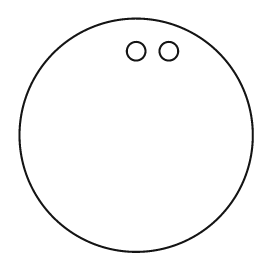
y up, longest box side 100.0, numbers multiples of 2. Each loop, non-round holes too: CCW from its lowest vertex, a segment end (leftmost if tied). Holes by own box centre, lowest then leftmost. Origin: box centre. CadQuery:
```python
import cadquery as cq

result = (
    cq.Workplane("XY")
    .moveTo(0.0, 0.0)
    .circle(50.0)
    .moveTo(0.0, 36.0)
    .circle(4.0)
    .moveTo(14.0, 36.0)
    .circle(4.0)
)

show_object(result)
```